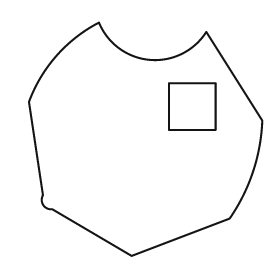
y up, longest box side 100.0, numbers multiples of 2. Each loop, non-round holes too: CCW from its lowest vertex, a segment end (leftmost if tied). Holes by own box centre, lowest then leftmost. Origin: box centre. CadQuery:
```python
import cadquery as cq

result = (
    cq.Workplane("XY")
    .moveTo(-6.0, -50.0)
    .lineTo(36.0, -34.0)
    .threePointArc((46.0, -14.0), (50.0, 8.0))
    .lineTo(26.0, 46.0)
    .threePointArc((2.0, 34.0), (-20.0, 50.0))
    .threePointArc((-38.0, 36.0), (-50.0, 16.0))
    .lineTo(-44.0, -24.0)
    .threePointArc((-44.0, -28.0), (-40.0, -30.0))
    .close()
    .moveTo(10.0, 4.0)
    .lineTo(30.0, 4.0)
    .lineTo(30.0, 24.0)
    .lineTo(10.0, 24.0)
    .close()
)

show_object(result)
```